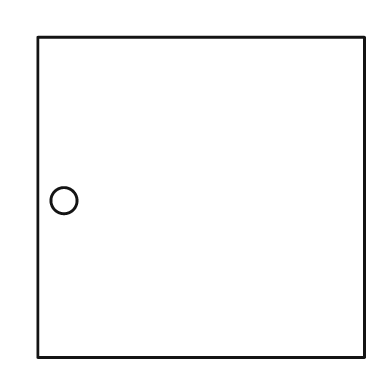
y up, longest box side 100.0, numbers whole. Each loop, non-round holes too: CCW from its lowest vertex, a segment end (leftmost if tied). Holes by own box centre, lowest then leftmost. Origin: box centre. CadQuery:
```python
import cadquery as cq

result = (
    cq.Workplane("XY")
    .moveTo(-50.0, -49.0)
    .lineTo(50.0, -49.0)
    .lineTo(50.0, 49.0)
    .lineTo(-50.0, 49.0)
    .close()
    .moveTo(-42.0, -1.0)
    .circle(4.0)
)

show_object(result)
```